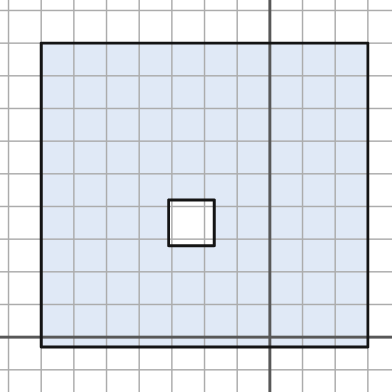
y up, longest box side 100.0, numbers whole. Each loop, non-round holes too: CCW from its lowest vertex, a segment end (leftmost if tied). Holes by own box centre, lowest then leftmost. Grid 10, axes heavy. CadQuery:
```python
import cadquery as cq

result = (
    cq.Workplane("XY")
    .moveTo(-70.0, -3.0)
    .lineTo(30.0, -3.0)
    .lineTo(30.0, 90.0)
    .lineTo(-70.0, 90.0)
    .close()
    .moveTo(-31.0, 28.0)
    .lineTo(-17.0, 28.0)
    .lineTo(-17.0, 42.0)
    .lineTo(-31.0, 42.0)
    .close()
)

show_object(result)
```